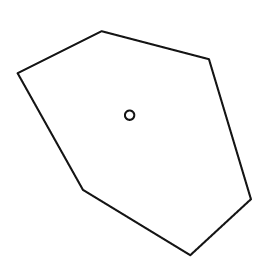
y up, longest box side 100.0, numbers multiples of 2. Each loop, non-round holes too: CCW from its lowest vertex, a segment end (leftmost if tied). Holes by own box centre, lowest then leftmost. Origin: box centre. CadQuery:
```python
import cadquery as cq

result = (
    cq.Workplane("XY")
    .moveTo(24.0, -48.0)
    .lineTo(50.0, -24.0)
    .lineTo(32.0, 36.0)
    .lineTo(-14.0, 48.0)
    .lineTo(-50.0, 30.0)
    .lineTo(-22.0, -20.0)
    .close()
    .moveTo(-2.0, 12.0)
    .circle(2.0)
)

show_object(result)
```